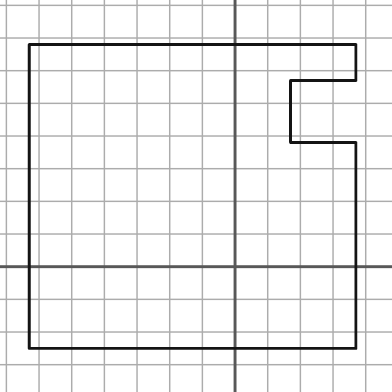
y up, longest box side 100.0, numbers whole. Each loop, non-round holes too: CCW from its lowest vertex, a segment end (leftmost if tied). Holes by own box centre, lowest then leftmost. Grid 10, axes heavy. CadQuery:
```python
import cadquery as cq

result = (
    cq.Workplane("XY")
    .moveTo(-63.0, -25.0)
    .lineTo(37.0, -25.0)
    .lineTo(37.0, 38.0)
    .lineTo(17.0, 38.0)
    .lineTo(17.0, 57.0)
    .lineTo(37.0, 57.0)
    .lineTo(37.0, 68.0)
    .lineTo(-63.0, 68.0)
    .close()
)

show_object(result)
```